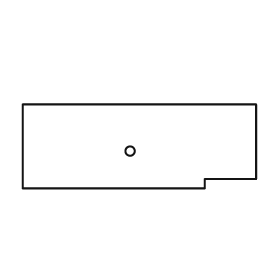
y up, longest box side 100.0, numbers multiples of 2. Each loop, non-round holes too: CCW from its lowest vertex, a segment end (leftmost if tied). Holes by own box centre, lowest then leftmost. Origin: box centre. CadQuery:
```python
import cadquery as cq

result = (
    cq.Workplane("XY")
    .moveTo(-50.0, -18.0)
    .lineTo(28.0, -18.0)
    .lineTo(28.0, -14.0)
    .lineTo(50.0, -14.0)
    .lineTo(50.0, 18.0)
    .lineTo(-50.0, 18.0)
    .close()
    .moveTo(-4.0, -2.0)
    .circle(2.0)
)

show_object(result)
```